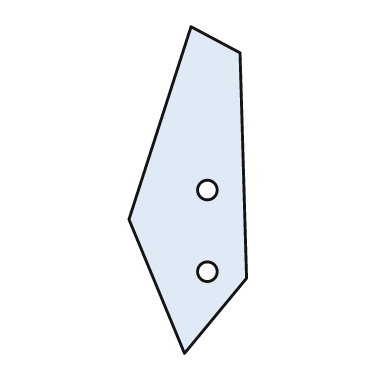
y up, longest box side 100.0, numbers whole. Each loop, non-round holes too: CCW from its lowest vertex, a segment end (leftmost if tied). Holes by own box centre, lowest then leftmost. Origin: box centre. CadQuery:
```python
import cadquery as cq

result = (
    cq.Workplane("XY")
    .moveTo(-1.0, -50.0)
    .lineTo(18.0, -27.0)
    .lineTo(16.0, 42.0)
    .lineTo(1.0, 50.0)
    .lineTo(-18.0, -9.0)
    .close()
    .moveTo(6.0, -25.0)
    .circle(3.0)
    .moveTo(6.0, 0.0)
    .circle(3.0)
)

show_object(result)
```